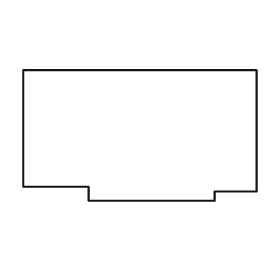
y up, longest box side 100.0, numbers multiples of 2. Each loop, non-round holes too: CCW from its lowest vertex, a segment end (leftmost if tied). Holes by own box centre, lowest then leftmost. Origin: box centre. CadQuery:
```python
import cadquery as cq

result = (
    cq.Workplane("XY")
    .moveTo(-22.0, -28.0)
    .lineTo(32.0, -28.0)
    .lineTo(32.0, -24.0)
    .lineTo(50.0, -24.0)
    .lineTo(50.0, 28.0)
    .lineTo(-50.0, 28.0)
    .lineTo(-50.0, -22.0)
    .lineTo(-22.0, -22.0)
    .close()
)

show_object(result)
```